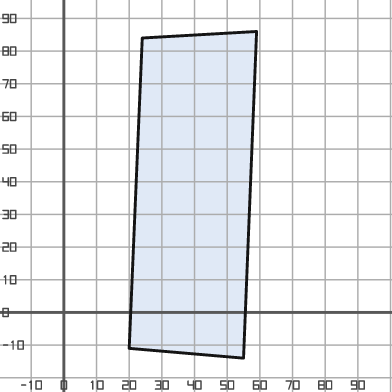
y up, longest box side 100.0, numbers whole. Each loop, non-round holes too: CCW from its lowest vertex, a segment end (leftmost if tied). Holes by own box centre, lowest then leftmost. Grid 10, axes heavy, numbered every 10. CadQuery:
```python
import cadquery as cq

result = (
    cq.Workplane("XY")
    .moveTo(55.0, -14.0)
    .lineTo(59.0, 86.0)
    .lineTo(24.0, 84.0)
    .lineTo(20.0, -11.0)
    .close()
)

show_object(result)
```